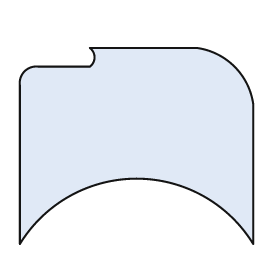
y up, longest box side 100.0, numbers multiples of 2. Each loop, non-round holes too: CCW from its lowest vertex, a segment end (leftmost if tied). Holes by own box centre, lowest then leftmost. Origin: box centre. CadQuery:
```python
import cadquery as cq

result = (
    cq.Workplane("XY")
    .moveTo(-50.0, -42.0)
    .threePointArc((0.0, -14.0), (50.0, -42.0))
    .lineTo(50.0, 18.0)
    .threePointArc((42.0, 34.0), (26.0, 42.0))
    .lineTo(-20.0, 42.0)
    .threePointArc((-18.0, 38.0), (-20.0, 34.0))
    .lineTo(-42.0, 34.0)
    .threePointArc((-48.0, 32.0), (-50.0, 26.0))
    .close()
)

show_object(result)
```